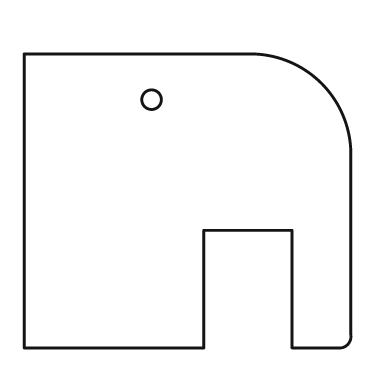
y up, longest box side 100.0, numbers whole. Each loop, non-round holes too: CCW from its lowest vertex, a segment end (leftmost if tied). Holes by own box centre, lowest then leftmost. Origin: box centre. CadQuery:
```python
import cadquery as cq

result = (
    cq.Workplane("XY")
    .moveTo(-50.0, -45.0)
    .lineTo(5.0, -45.0)
    .lineTo(5.0, -9.0)
    .lineTo(32.0, -9.0)
    .lineTo(32.0, -45.0)
    .lineTo(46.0, -45.0)
    .threePointArc((49.0, -44.0), (50.0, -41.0))
    .lineTo(50.0, 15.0)
    .threePointArc((41.0, 36.0), (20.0, 45.0))
    .lineTo(-50.0, 45.0)
    .close()
    .moveTo(-11.0, 31.0)
    .circle(3.0)
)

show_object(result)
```